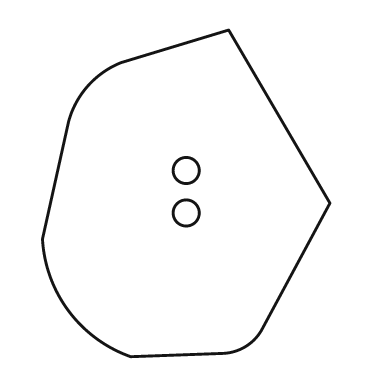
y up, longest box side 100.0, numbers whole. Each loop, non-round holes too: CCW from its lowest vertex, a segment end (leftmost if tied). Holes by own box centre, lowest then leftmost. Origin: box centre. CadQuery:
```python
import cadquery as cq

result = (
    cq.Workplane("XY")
    .moveTo(-17.0, -50.0)
    .lineTo(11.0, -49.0)
    .threePointArc((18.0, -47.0), (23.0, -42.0))
    .lineTo(44.0, -3.0)
    .lineTo(13.0, 50.0)
    .lineTo(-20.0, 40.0)
    .threePointArc((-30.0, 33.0), (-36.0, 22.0))
    .lineTo(-44.0, -14.0)
    .threePointArc((-36.0, -36.0), (-17.0, -50.0))
    .close()
    .moveTo(0.0, -6.0)
    .circle(4.0)
    .moveTo(0.0, 7.0)
    .circle(4.0)
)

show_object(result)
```